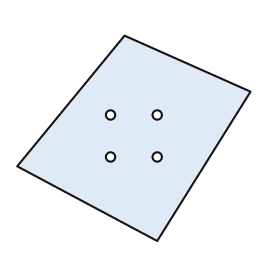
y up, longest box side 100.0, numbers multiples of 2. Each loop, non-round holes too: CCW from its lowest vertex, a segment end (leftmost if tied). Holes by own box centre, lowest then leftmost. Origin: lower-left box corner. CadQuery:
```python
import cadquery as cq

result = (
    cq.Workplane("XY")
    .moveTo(60.0, 0.0)
    .lineTo(100.0, 64.0)
    .lineTo(46.0, 88.0)
    .lineTo(0.0, 32.0)
    .close()
    .moveTo(40.0, 36.0)
    .circle(2.0)
    .moveTo(60.0, 36.0)
    .circle(2.0)
    .moveTo(40.0, 54.0)
    .circle(2.0)
    .moveTo(60.0, 54.0)
    .circle(2.0)
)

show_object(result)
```